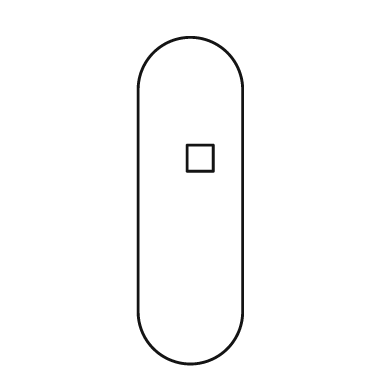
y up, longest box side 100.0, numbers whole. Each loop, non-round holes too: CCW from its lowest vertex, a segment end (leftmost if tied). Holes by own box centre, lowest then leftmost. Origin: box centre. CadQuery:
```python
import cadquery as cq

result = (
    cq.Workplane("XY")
    .moveTo(-16.0, -34.0)
    .threePointArc((0.0, -50.0), (16.0, -34.0))
    .lineTo(16.0, 34.0)
    .threePointArc((0.0, 50.0), (-16.0, 34.0))
    .close()
    .moveTo(-1.0, 9.0)
    .lineTo(7.0, 9.0)
    .lineTo(7.0, 17.0)
    .lineTo(-1.0, 17.0)
    .close()
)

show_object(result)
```